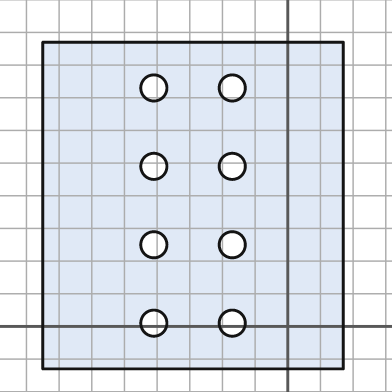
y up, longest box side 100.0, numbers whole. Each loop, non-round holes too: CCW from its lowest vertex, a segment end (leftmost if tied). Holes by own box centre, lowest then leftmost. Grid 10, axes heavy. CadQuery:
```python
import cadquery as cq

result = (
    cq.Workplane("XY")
    .moveTo(-75.0, -13.0)
    .lineTo(17.0, -13.0)
    .lineTo(17.0, 87.0)
    .lineTo(-75.0, 87.0)
    .close()
    .moveTo(-41.0, 1.0)
    .circle(4.0)
    .moveTo(-17.0, 1.0)
    .circle(4.0)
    .moveTo(-41.0, 25.0)
    .circle(4.0)
    .moveTo(-17.0, 25.0)
    .circle(4.0)
    .moveTo(-41.0, 49.0)
    .circle(4.0)
    .moveTo(-17.0, 49.0)
    .circle(4.0)
    .moveTo(-41.0, 73.0)
    .circle(4.0)
    .moveTo(-17.0, 73.0)
    .circle(4.0)
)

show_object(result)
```